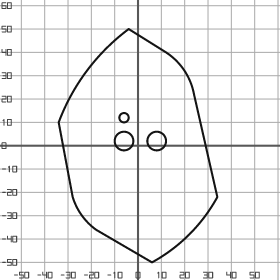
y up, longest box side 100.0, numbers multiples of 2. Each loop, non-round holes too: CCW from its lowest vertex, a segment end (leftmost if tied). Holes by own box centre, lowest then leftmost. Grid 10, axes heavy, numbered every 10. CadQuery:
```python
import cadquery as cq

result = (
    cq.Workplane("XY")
    .moveTo(6.0, -50.0)
    .threePointArc((22.0, -38.0), (34.0, -22.0))
    .lineTo(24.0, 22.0)
    .threePointArc((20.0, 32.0), (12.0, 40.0))
    .lineTo(-4.0, 50.0)
    .threePointArc((-22.0, 32.0), (-34.0, 10.0))
    .lineTo(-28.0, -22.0)
    .threePointArc((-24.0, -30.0), (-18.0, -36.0))
    .close()
    .moveTo(-6.0, 2.0)
    .circle(4.0)
    .moveTo(8.0, 2.0)
    .circle(4.0)
    .moveTo(-6.0, 12.0)
    .circle(2.0)
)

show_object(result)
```